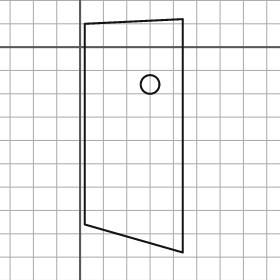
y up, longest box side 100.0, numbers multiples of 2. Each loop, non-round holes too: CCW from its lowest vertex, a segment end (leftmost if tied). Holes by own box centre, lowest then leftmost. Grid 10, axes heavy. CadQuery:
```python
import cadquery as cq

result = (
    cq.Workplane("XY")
    .moveTo(44.0, -88.0)
    .lineTo(44.0, 12.0)
    .lineTo(2.0, 10.0)
    .lineTo(2.0, -76.0)
    .close()
    .moveTo(30.0, -16.0)
    .circle(4.0)
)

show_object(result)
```